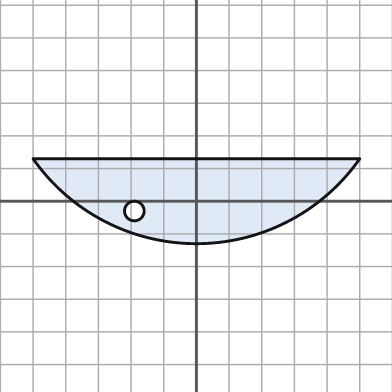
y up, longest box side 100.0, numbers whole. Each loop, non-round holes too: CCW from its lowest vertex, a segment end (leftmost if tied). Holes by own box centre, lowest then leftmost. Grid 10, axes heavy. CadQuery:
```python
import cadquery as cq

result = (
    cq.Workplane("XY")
    .moveTo(-50.0, 13.0)
    .threePointArc((0.0, -13.0), (50.0, 13.0))
    .close()
    .moveTo(-19.0, -3.0)
    .circle(3.0)
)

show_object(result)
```